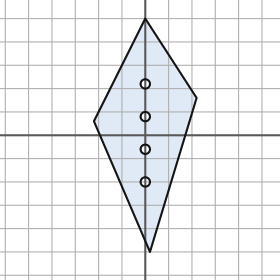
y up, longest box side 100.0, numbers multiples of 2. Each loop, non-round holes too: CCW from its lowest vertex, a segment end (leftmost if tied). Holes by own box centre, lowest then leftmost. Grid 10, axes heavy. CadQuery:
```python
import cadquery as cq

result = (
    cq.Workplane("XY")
    .moveTo(2.0, -50.0)
    .lineTo(22.0, 16.0)
    .lineTo(0.0, 50.0)
    .lineTo(-22.0, 6.0)
    .close()
    .moveTo(0.0, -20.0)
    .circle(2.0)
    .moveTo(0.0, -6.0)
    .circle(2.0)
    .moveTo(0.0, 8.0)
    .circle(2.0)
    .moveTo(0.0, 22.0)
    .circle(2.0)
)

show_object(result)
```